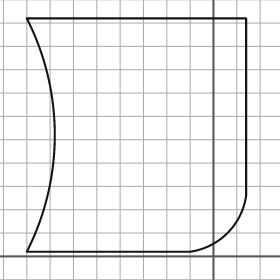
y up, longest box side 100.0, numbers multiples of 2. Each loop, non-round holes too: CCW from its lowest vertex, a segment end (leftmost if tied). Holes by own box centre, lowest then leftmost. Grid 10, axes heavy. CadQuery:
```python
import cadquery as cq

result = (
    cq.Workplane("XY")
    .moveTo(-80.0, 2.0)
    .lineTo(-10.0, 2.0)
    .threePointArc((6.0, 10.0), (14.0, 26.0))
    .lineTo(14.0, 102.0)
    .lineTo(-80.0, 102.0)
    .threePointArc((-68.0, 52.0), (-80.0, 2.0))
    .close()
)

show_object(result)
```